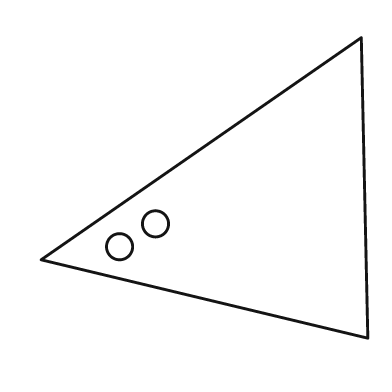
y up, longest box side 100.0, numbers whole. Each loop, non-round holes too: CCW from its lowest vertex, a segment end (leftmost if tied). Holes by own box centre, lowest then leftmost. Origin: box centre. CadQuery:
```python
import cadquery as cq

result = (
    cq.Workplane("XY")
    .moveTo(50.0, -46.0)
    .lineTo(48.0, 46.0)
    .lineTo(-50.0, -22.0)
    .close()
    .moveTo(-26.0, -18.0)
    .circle(4.0)
    .moveTo(-15.0, -11.0)
    .circle(4.0)
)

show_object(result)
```